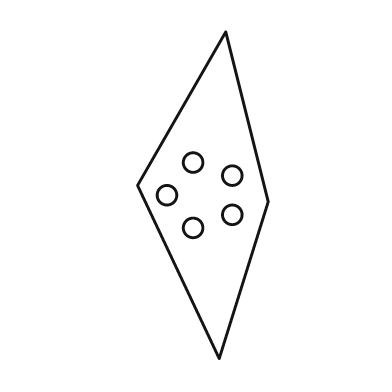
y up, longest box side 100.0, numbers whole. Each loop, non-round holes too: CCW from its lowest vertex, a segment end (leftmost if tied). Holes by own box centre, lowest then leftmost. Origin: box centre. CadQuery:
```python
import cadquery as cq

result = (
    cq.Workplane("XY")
    .moveTo(5.0, -50.0)
    .lineTo(20.0, -2.0)
    .lineTo(7.0, 50.0)
    .lineTo(-20.0, 3.0)
    .close()
    .moveTo(-3.0, -10.0)
    .circle(3.0)
    .moveTo(9.0, -6.0)
    .circle(3.0)
    .moveTo(-11.0, 0.0)
    .circle(3.0)
    .moveTo(9.0, 6.0)
    .circle(3.0)
    .moveTo(-3.0, 10.0)
    .circle(3.0)
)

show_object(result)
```